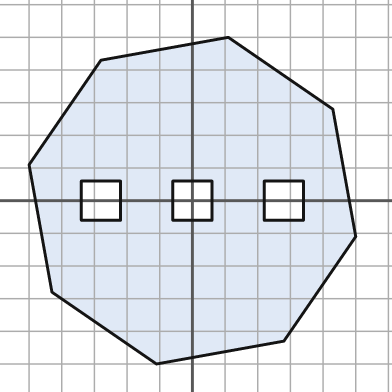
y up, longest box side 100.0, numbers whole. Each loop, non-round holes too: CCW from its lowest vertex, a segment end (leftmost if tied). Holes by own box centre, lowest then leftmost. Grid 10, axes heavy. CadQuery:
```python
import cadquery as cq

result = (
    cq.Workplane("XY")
    .moveTo(-11.0, -50.0)
    .lineTo(28.0, -43.0)
    .lineTo(50.0, -11.0)
    .lineTo(43.0, 28.0)
    .lineTo(11.0, 50.0)
    .lineTo(-28.0, 43.0)
    .lineTo(-50.0, 11.0)
    .lineTo(-43.0, -28.0)
    .close()
    .moveTo(-34.0, -6.0)
    .lineTo(-22.0, -6.0)
    .lineTo(-22.0, 6.0)
    .lineTo(-34.0, 6.0)
    .close()
    .moveTo(-6.0, -6.0)
    .lineTo(6.0, -6.0)
    .lineTo(6.0, 6.0)
    .lineTo(-6.0, 6.0)
    .close()
    .moveTo(22.0, -6.0)
    .lineTo(34.0, -6.0)
    .lineTo(34.0, 6.0)
    .lineTo(22.0, 6.0)
    .close()
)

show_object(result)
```